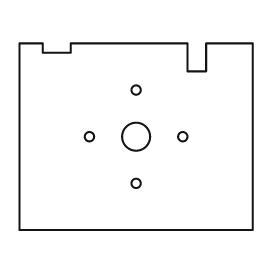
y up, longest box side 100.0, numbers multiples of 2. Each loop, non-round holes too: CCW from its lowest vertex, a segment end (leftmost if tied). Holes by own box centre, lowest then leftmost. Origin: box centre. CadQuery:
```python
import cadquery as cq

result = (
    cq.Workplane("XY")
    .moveTo(-50.0, -40.0)
    .lineTo(50.0, -40.0)
    .lineTo(50.0, 40.0)
    .lineTo(30.0, 40.0)
    .lineTo(30.0, 28.0)
    .lineTo(22.0, 28.0)
    .lineTo(22.0, 40.0)
    .lineTo(-28.0, 40.0)
    .lineTo(-28.0, 36.0)
    .lineTo(-40.0, 36.0)
    .lineTo(-40.0, 40.0)
    .lineTo(-50.0, 40.0)
    .close()
    .moveTo(0.0, -20.0)
    .circle(2.0)
    .moveTo(-20.0, 0.0)
    .circle(2.0)
    .moveTo(0.0, 0.0)
    .circle(6.0)
    .moveTo(20.0, 0.0)
    .circle(2.0)
    .moveTo(0.0, 20.0)
    .circle(2.0)
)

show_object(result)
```